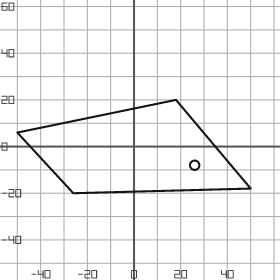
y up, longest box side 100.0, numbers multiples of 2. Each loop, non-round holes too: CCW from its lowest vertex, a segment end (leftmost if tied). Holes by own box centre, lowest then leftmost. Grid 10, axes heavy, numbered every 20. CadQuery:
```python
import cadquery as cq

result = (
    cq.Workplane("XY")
    .moveTo(-26.0, -20.0)
    .lineTo(50.0, -18.0)
    .lineTo(18.0, 20.0)
    .lineTo(-50.0, 6.0)
    .close()
    .moveTo(26.0, -8.0)
    .circle(2.0)
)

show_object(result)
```